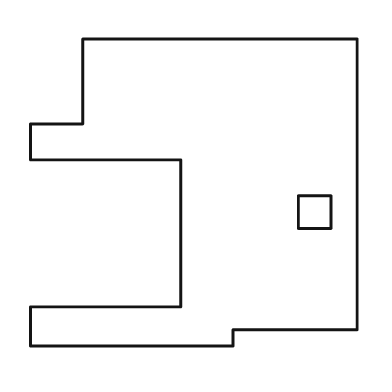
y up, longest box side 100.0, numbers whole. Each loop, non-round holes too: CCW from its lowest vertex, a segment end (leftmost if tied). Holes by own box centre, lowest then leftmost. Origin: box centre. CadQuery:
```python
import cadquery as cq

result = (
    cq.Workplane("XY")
    .moveTo(-50.0, -47.0)
    .lineTo(12.0, -47.0)
    .lineTo(12.0, -42.0)
    .lineTo(50.0, -42.0)
    .lineTo(50.0, 47.0)
    .lineTo(-34.0, 47.0)
    .lineTo(-34.0, 21.0)
    .lineTo(-50.0, 21.0)
    .lineTo(-50.0, 10.0)
    .lineTo(-4.0, 10.0)
    .lineTo(-4.0, -35.0)
    .lineTo(-50.0, -35.0)
    .close()
    .moveTo(32.0, -11.0)
    .lineTo(42.0, -11.0)
    .lineTo(42.0, -1.0)
    .lineTo(32.0, -1.0)
    .close()
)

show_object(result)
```